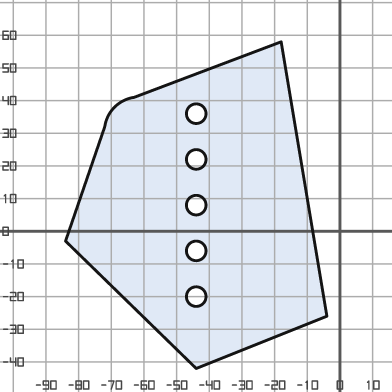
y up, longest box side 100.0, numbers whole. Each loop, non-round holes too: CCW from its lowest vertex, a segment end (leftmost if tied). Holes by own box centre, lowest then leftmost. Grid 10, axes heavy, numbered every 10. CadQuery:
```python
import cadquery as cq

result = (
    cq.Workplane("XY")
    .moveTo(-44.0, -42.0)
    .lineTo(-4.0, -26.0)
    .lineTo(-18.0, 58.0)
    .lineTo(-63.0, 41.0)
    .threePointArc((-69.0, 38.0), (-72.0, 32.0))
    .lineTo(-84.0, -3.0)
    .close()
    .moveTo(-44.0, -20.0)
    .circle(3.0)
    .moveTo(-44.0, -6.0)
    .circle(3.0)
    .moveTo(-44.0, 8.0)
    .circle(3.0)
    .moveTo(-44.0, 22.0)
    .circle(3.0)
    .moveTo(-44.0, 36.0)
    .circle(3.0)
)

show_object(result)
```